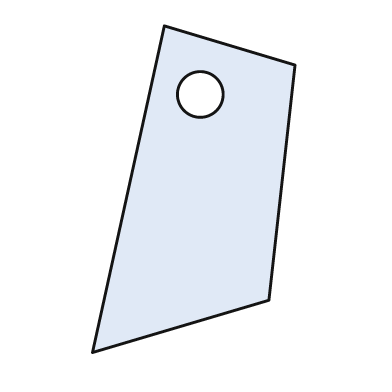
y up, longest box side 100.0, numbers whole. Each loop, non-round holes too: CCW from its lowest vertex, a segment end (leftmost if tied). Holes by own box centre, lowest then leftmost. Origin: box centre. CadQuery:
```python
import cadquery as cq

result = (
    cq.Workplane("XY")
    .moveTo(-31.0, -50.0)
    .lineTo(23.0, -34.0)
    .lineTo(31.0, 38.0)
    .lineTo(-9.0, 50.0)
    .close()
    .moveTo(2.0, 29.0)
    .circle(7.0)
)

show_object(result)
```